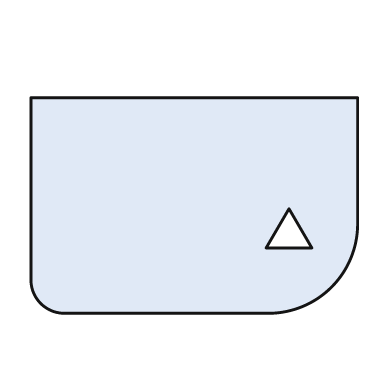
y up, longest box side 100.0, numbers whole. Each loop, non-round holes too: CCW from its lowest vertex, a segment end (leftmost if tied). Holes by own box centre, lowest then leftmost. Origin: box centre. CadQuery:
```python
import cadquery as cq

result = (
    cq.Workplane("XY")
    .moveTo(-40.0, -33.0)
    .lineTo(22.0, -33.0)
    .threePointArc((42.0, -25.0), (50.0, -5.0))
    .lineTo(50.0, 33.0)
    .lineTo(-50.0, 33.0)
    .lineTo(-50.0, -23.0)
    .threePointArc((-47.0, -30.0), (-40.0, -33.0))
    .close()
    .moveTo(22.0, -13.0)
    .lineTo(36.0, -13.0)
    .lineTo(29.0, -1.0)
    .close()
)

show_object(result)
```